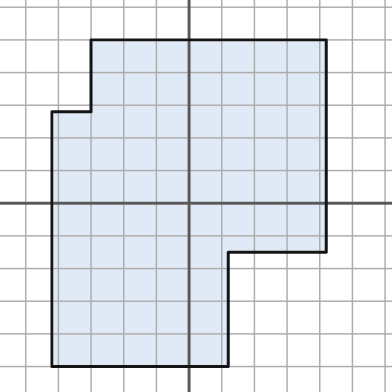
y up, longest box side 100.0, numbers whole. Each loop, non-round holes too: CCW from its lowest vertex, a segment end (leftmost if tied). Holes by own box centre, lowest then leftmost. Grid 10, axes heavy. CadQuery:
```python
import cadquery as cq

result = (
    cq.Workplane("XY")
    .moveTo(-42.0, -50.0)
    .lineTo(12.0, -50.0)
    .lineTo(12.0, -15.0)
    .lineTo(42.0, -15.0)
    .lineTo(42.0, 50.0)
    .lineTo(-30.0, 50.0)
    .lineTo(-30.0, 28.0)
    .lineTo(-42.0, 28.0)
    .close()
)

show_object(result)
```